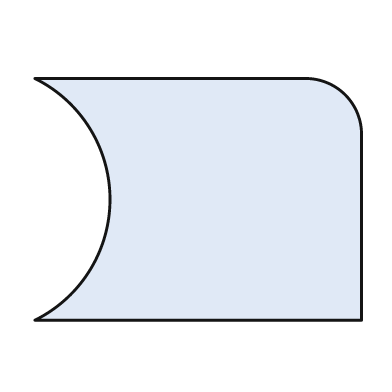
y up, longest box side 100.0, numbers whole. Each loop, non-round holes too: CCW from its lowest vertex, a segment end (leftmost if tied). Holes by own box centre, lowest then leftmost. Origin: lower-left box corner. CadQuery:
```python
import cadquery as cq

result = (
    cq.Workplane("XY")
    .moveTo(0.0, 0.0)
    .lineTo(100.0, 0.0)
    .lineTo(100.0, 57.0)
    .threePointArc((95.0, 69.0), (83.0, 74.0))
    .lineTo(0.0, 74.0)
    .threePointArc((23.0, 37.0), (0.0, 0.0))
    .close()
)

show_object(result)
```